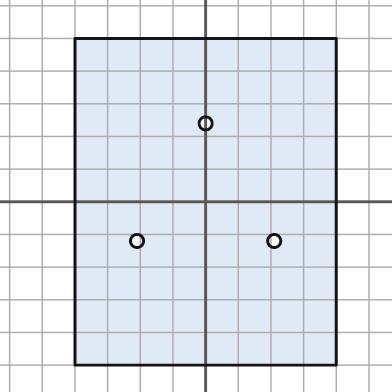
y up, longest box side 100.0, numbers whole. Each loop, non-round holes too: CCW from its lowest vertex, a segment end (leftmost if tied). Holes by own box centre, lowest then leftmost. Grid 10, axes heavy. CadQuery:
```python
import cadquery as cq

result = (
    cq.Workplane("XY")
    .moveTo(-40.0, -50.0)
    .lineTo(40.0, -50.0)
    .lineTo(40.0, 50.0)
    .lineTo(-40.0, 50.0)
    .close()
    .moveTo(-21.0, -12.0)
    .circle(2.0)
    .moveTo(21.0, -12.0)
    .circle(2.0)
    .moveTo(0.0, 24.0)
    .circle(2.0)
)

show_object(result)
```